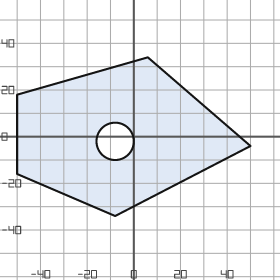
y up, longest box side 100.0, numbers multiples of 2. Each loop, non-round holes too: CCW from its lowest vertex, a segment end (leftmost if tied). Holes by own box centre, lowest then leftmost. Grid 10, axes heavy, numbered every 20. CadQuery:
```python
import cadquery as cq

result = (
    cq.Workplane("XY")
    .moveTo(-8.0, -34.0)
    .lineTo(50.0, -4.0)
    .lineTo(6.0, 34.0)
    .lineTo(-50.0, 18.0)
    .lineTo(-50.0, -16.0)
    .close()
    .moveTo(-8.0, -2.0)
    .circle(8.0)
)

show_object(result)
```